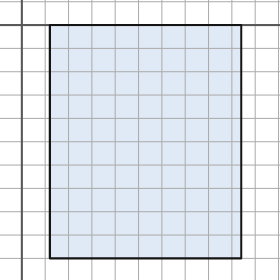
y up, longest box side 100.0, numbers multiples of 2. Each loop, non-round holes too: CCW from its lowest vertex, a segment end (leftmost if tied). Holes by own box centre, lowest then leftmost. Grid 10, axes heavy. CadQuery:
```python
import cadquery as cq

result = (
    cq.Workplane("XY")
    .moveTo(12.0, -100.0)
    .lineTo(94.0, -100.0)
    .lineTo(94.0, 0.0)
    .lineTo(12.0, 0.0)
    .close()
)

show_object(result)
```